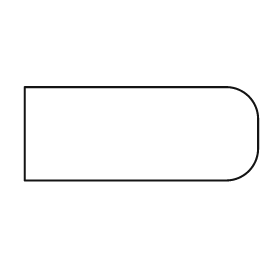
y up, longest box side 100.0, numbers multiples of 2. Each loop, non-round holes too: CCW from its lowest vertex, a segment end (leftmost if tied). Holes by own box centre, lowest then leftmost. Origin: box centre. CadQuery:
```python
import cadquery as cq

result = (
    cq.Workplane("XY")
    .moveTo(-50.0, -20.0)
    .lineTo(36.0, -20.0)
    .threePointArc((46.0, -16.0), (50.0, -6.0))
    .lineTo(50.0, 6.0)
    .threePointArc((46.0, 16.0), (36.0, 20.0))
    .lineTo(-50.0, 20.0)
    .close()
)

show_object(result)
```